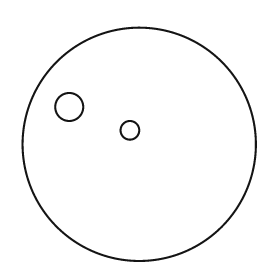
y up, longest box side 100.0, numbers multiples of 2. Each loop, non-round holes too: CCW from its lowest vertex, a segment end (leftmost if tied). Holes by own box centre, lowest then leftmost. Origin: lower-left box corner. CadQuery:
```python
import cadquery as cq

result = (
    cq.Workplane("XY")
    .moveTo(50.0, 50.0)
    .circle(50.0)
    .moveTo(46.0, 56.0)
    .circle(4.0)
    .moveTo(20.0, 66.0)
    .circle(6.0)
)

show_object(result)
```